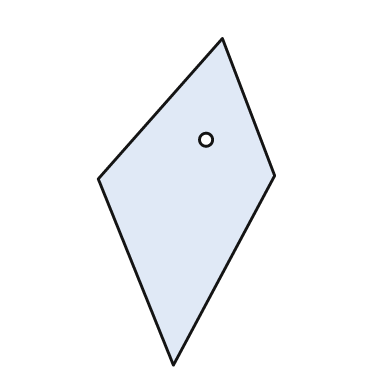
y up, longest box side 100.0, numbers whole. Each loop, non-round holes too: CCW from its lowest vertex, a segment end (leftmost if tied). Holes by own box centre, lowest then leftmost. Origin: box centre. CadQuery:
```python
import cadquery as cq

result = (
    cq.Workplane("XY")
    .moveTo(-4.0, -50.0)
    .lineTo(27.0, 8.0)
    .lineTo(11.0, 50.0)
    .lineTo(-27.0, 7.0)
    .close()
    .moveTo(6.0, 19.0)
    .circle(2.0)
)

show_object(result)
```